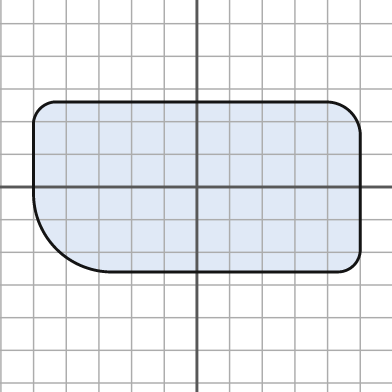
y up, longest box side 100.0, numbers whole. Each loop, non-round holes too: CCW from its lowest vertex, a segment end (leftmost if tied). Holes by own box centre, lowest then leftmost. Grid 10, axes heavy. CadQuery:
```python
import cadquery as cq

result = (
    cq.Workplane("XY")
    .moveTo(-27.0, -26.0)
    .lineTo(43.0, -26.0)
    .threePointArc((48.0, -24.0), (50.0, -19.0))
    .lineTo(50.0, 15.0)
    .threePointArc((47.0, 23.0), (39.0, 26.0))
    .lineTo(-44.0, 26.0)
    .threePointArc((-48.0, 24.0), (-50.0, 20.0))
    .lineTo(-50.0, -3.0)
    .threePointArc((-43.0, -19.0), (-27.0, -26.0))
    .close()
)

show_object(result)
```